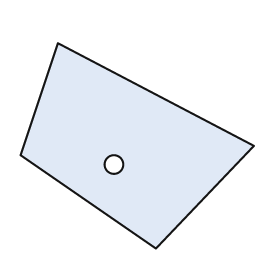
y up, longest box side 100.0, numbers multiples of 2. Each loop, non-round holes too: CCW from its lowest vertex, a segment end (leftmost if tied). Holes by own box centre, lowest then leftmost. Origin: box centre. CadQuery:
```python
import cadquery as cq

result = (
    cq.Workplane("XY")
    .moveTo(8.0, -44.0)
    .lineTo(50.0, 0.0)
    .lineTo(-34.0, 44.0)
    .lineTo(-50.0, -4.0)
    .close()
    .moveTo(-10.0, -8.0)
    .circle(4.0)
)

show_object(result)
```